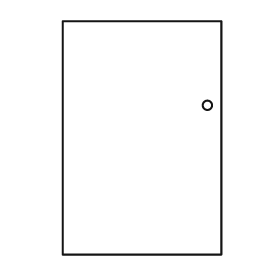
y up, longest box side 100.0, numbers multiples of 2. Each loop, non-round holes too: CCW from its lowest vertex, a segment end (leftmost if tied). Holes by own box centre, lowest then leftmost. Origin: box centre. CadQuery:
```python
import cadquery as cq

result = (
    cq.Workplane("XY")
    .moveTo(-34.0, -50.0)
    .lineTo(34.0, -50.0)
    .lineTo(34.0, 50.0)
    .lineTo(-34.0, 50.0)
    .close()
    .moveTo(28.0, 14.0)
    .circle(2.0)
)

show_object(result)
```